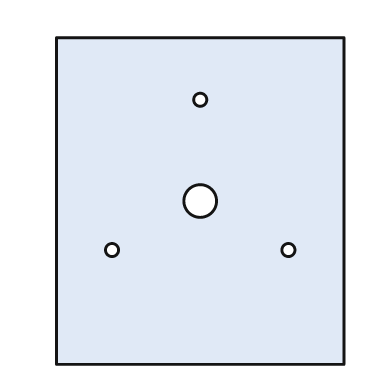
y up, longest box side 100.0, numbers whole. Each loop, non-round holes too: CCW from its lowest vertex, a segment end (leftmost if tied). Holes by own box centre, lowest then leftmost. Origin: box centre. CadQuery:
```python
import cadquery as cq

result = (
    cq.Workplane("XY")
    .moveTo(-44.0, -50.0)
    .lineTo(44.0, -50.0)
    .lineTo(44.0, 50.0)
    .lineTo(-44.0, 50.0)
    .close()
    .moveTo(-27.0, -15.0)
    .circle(2.0)
    .moveTo(27.0, -15.0)
    .circle(2.0)
    .moveTo(0.0, 0.0)
    .circle(5.0)
    .moveTo(0.0, 31.0)
    .circle(2.0)
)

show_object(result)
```